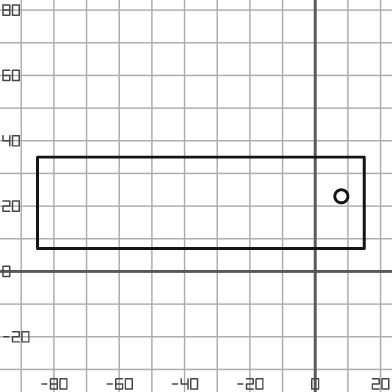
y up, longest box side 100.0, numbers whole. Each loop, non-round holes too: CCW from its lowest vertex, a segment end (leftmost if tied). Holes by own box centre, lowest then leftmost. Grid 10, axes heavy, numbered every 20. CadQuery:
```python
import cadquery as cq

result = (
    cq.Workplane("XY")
    .moveTo(-85.0, 7.0)
    .lineTo(15.0, 7.0)
    .lineTo(15.0, 35.0)
    .lineTo(-85.0, 35.0)
    .close()
    .moveTo(8.0, 23.0)
    .circle(2.0)
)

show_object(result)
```